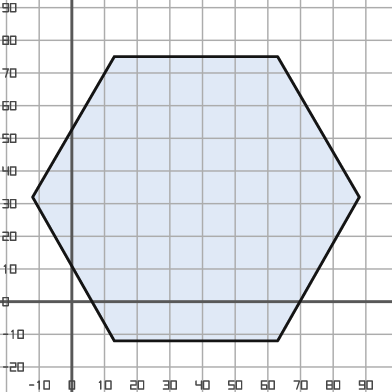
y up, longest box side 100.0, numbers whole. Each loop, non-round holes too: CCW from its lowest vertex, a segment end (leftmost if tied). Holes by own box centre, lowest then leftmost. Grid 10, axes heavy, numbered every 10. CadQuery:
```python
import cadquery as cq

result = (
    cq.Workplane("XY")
    .moveTo(13.0, -12.0)
    .lineTo(63.0, -12.0)
    .lineTo(88.0, 32.0)
    .lineTo(63.0, 75.0)
    .lineTo(13.0, 75.0)
    .lineTo(-12.0, 32.0)
    .close()
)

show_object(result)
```